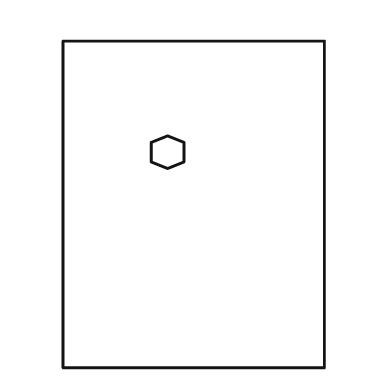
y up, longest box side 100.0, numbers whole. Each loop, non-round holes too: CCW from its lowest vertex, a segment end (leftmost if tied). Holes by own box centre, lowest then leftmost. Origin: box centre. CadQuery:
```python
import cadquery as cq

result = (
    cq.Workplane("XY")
    .moveTo(-40.0, -50.0)
    .lineTo(40.0, -50.0)
    .lineTo(40.0, 50.0)
    .lineTo(-40.0, 50.0)
    .close()
    .moveTo(-8.0, 11.0)
    .lineTo(-3.0, 13.0)
    .lineTo(-3.0, 19.0)
    .lineTo(-8.0, 21.0)
    .lineTo(-13.0, 19.0)
    .lineTo(-13.0, 13.0)
    .close()
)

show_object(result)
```